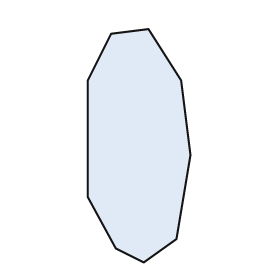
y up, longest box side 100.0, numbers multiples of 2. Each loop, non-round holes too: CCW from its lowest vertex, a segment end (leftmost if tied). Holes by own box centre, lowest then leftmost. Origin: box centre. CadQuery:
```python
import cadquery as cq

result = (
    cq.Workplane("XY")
    .moveTo(2.0, -50.0)
    .lineTo(16.0, -40.0)
    .lineTo(22.0, -4.0)
    .lineTo(18.0, 28.0)
    .lineTo(4.0, 50.0)
    .lineTo(-12.0, 48.0)
    .lineTo(-22.0, 28.0)
    .lineTo(-22.0, -22.0)
    .lineTo(-10.0, -44.0)
    .close()
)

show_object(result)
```